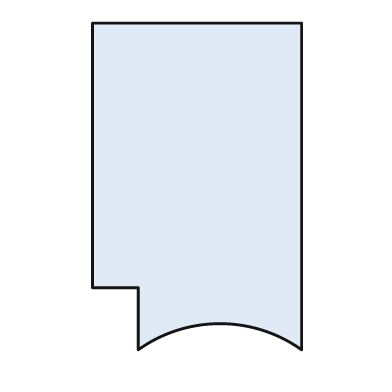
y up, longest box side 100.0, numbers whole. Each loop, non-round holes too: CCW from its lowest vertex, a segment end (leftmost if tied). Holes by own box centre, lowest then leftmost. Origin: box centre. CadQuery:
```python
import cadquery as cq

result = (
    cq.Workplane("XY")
    .moveTo(-18.0, -50.0)
    .threePointArc((7.0, -42.0), (32.0, -50.0))
    .lineTo(32.0, 50.0)
    .lineTo(-32.0, 50.0)
    .lineTo(-32.0, -31.0)
    .lineTo(-18.0, -31.0)
    .close()
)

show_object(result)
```